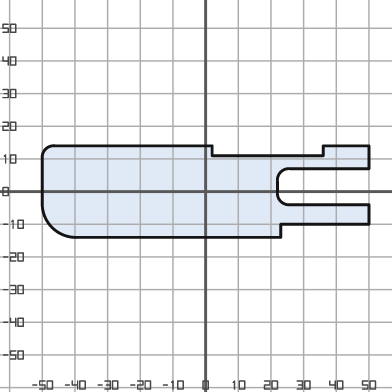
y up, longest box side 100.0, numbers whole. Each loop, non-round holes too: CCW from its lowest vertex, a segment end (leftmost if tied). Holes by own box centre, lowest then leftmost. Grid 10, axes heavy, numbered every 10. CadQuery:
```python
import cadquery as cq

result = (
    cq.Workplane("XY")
    .moveTo(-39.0, -14.0)
    .lineTo(23.0, -14.0)
    .lineTo(23.0, -10.0)
    .lineTo(50.0, -10.0)
    .lineTo(50.0, -4.0)
    .lineTo(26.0, -4.0)
    .threePointArc((23.0, -3.0), (22.0, 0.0))
    .lineTo(22.0, 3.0)
    .threePointArc((23.0, 6.0), (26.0, 7.0))
    .lineTo(50.0, 7.0)
    .lineTo(50.0, 14.0)
    .lineTo(36.0, 14.0)
    .lineTo(36.0, 11.0)
    .lineTo(2.0, 11.0)
    .lineTo(2.0, 14.0)
    .lineTo(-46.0, 14.0)
    .threePointArc((-49.0, 13.0), (-50.0, 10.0))
    .lineTo(-50.0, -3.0)
    .threePointArc((-47.0, -11.0), (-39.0, -14.0))
    .close()
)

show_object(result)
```